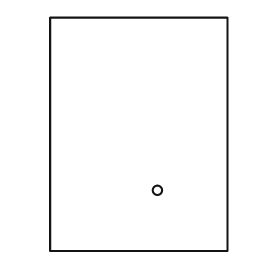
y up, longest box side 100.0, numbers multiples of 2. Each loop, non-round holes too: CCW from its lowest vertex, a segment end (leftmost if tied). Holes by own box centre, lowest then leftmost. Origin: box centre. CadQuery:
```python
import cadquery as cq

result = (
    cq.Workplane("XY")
    .moveTo(-38.0, -50.0)
    .lineTo(38.0, -50.0)
    .lineTo(38.0, 50.0)
    .lineTo(-38.0, 50.0)
    .close()
    .moveTo(8.0, -24.0)
    .circle(2.0)
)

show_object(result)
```